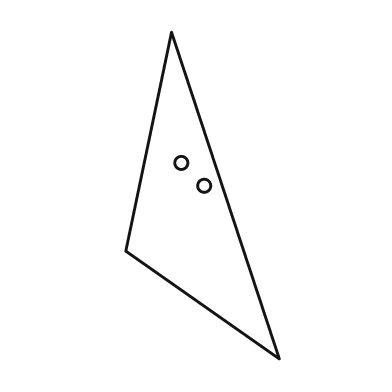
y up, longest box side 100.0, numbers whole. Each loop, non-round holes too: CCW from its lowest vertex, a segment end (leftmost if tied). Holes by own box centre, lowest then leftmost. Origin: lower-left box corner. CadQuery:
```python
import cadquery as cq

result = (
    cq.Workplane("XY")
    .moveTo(47.0, 0.0)
    .lineTo(14.0, 100.0)
    .lineTo(0.0, 33.0)
    .close()
    .moveTo(24.0, 53.0)
    .circle(2.0)
    .moveTo(17.0, 60.0)
    .circle(2.0)
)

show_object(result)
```